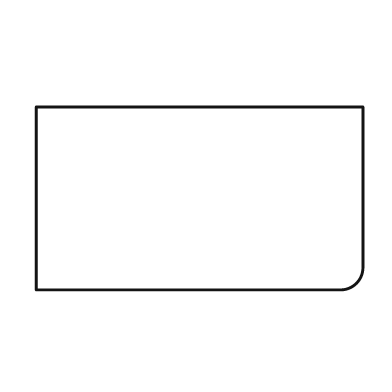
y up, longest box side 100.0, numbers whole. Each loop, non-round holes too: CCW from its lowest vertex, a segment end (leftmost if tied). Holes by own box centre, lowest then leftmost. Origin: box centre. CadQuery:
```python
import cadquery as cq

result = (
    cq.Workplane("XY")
    .moveTo(-50.0, -28.0)
    .lineTo(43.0, -28.0)
    .threePointArc((48.0, -26.0), (50.0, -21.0))
    .lineTo(50.0, 28.0)
    .lineTo(-50.0, 28.0)
    .close()
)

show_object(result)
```